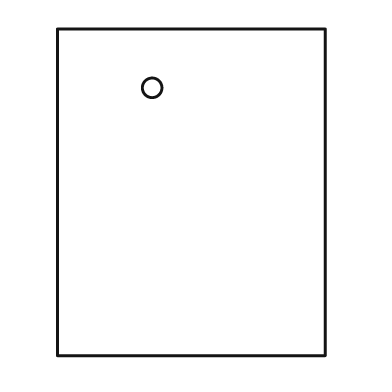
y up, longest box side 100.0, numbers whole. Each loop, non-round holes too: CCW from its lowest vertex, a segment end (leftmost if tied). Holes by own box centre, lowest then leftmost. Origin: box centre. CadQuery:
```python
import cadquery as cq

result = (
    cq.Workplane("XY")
    .moveTo(-41.0, -50.0)
    .lineTo(41.0, -50.0)
    .lineTo(41.0, 50.0)
    .lineTo(-41.0, 50.0)
    .close()
    .moveTo(-12.0, 32.0)
    .circle(3.0)
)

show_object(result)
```